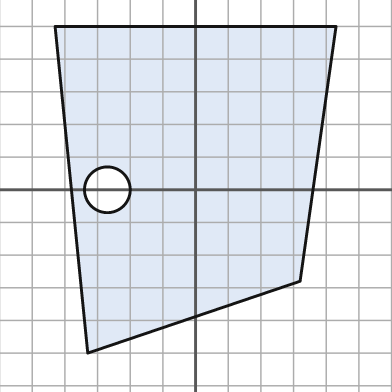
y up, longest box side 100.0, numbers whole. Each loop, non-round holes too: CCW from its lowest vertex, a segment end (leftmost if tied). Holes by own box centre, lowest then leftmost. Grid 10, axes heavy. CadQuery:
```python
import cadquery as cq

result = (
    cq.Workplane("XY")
    .moveTo(-33.0, -50.0)
    .lineTo(32.0, -28.0)
    .lineTo(43.0, 50.0)
    .lineTo(-43.0, 50.0)
    .close()
    .moveTo(-27.0, 0.0)
    .circle(7.0)
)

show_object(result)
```